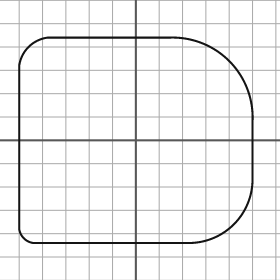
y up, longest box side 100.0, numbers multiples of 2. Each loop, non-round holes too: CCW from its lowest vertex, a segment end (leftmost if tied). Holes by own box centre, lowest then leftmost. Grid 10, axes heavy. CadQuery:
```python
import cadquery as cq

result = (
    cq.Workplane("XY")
    .moveTo(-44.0, -44.0)
    .lineTo(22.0, -44.0)
    .threePointArc((42.0, -36.0), (50.0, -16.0))
    .lineTo(50.0, 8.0)
    .threePointArc((40.0, 34.0), (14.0, 44.0))
    .lineTo(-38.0, 44.0)
    .threePointArc((-46.0, 40.0), (-50.0, 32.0))
    .lineTo(-50.0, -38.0)
    .threePointArc((-48.0, -42.0), (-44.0, -44.0))
    .close()
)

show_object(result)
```